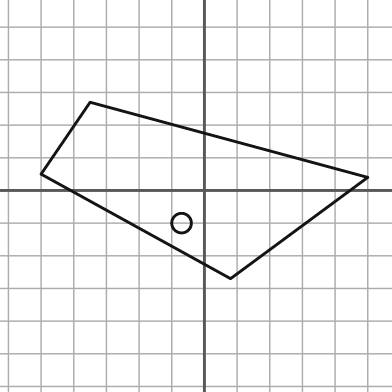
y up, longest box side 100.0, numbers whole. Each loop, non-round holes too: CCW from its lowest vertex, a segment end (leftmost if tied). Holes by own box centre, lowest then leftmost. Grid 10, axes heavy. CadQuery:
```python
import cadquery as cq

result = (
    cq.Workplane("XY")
    .moveTo(8.0, -27.0)
    .lineTo(50.0, 4.0)
    .lineTo(-35.0, 27.0)
    .lineTo(-50.0, 5.0)
    .close()
    .moveTo(-7.0, -10.0)
    .circle(3.0)
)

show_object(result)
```